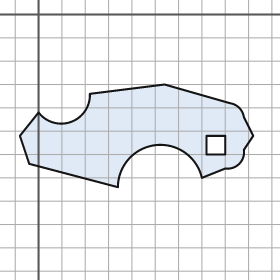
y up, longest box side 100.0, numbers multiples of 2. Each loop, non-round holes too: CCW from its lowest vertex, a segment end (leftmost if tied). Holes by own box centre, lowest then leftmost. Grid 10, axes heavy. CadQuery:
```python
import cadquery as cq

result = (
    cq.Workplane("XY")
    .moveTo(34.0, -74.0)
    .threePointArc((50.0, -56.0), (70.0, -70.0))
    .lineTo(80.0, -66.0)
    .threePointArc((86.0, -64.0), (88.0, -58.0))
    .lineTo(92.0, -52.0)
    .lineTo(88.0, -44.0)
    .threePointArc((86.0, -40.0), (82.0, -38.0))
    .lineTo(54.0, -30.0)
    .lineTo(22.0, -34.0)
    .threePointArc((14.0, -46.0), (0.0, -42.0))
    .lineTo(-8.0, -52.0)
    .lineTo(-4.0, -64.0)
    .close()
    .moveTo(72.0, -60.0)
    .lineTo(80.0, -60.0)
    .lineTo(80.0, -52.0)
    .lineTo(72.0, -52.0)
    .close()
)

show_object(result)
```